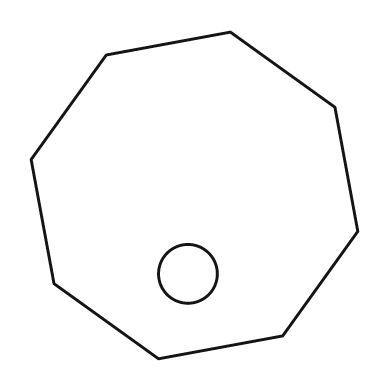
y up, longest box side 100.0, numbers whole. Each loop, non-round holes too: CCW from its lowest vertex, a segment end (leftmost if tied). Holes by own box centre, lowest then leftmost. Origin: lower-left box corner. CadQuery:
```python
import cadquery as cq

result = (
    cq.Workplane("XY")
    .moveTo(39.0, 0.0)
    .lineTo(77.0, 7.0)
    .lineTo(100.0, 39.0)
    .lineTo(93.0, 77.0)
    .lineTo(61.0, 100.0)
    .lineTo(23.0, 93.0)
    .lineTo(0.0, 61.0)
    .lineTo(7.0, 23.0)
    .close()
    .moveTo(48.0, 26.0)
    .circle(9.0)
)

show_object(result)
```